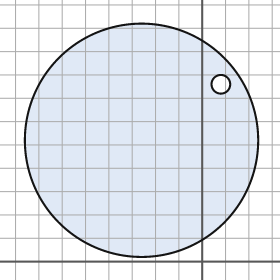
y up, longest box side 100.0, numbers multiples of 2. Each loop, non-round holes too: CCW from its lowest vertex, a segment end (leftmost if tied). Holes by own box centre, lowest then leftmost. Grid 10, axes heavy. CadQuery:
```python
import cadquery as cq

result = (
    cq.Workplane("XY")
    .moveTo(-26.0, 52.0)
    .circle(50.0)
    .moveTo(8.0, 76.0)
    .circle(4.0)
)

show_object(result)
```